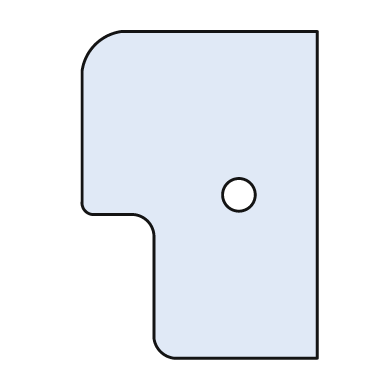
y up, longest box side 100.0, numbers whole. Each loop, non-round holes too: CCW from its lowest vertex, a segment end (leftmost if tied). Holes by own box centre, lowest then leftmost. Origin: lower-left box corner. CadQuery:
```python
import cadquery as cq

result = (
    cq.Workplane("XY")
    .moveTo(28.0, 0.0)
    .lineTo(72.0, 0.0)
    .lineTo(72.0, 100.0)
    .lineTo(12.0, 100.0)
    .threePointArc((4.0, 96.0), (0.0, 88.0))
    .lineTo(0.0, 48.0)
    .threePointArc((1.0, 45.0), (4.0, 44.0))
    .lineTo(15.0, 44.0)
    .threePointArc((20.0, 42.0), (22.0, 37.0))
    .lineTo(22.0, 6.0)
    .threePointArc((24.0, 2.0), (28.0, 0.0))
    .close()
    .moveTo(48.0, 50.0)
    .circle(5.0)
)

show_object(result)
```